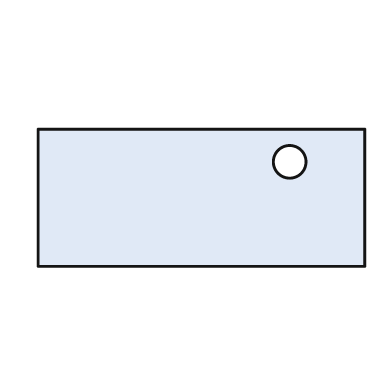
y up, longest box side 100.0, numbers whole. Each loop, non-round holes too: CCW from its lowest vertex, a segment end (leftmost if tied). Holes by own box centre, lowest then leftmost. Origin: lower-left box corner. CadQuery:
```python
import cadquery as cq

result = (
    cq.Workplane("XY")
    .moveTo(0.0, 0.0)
    .lineTo(100.0, 0.0)
    .lineTo(100.0, 42.0)
    .lineTo(0.0, 42.0)
    .close()
    .moveTo(77.0, 32.0)
    .circle(5.0)
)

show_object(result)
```